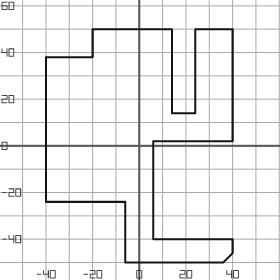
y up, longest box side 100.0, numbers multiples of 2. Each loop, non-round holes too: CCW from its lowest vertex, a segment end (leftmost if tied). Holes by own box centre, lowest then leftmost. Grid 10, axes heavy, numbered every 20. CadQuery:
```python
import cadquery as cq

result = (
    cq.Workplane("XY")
    .moveTo(-6.0, -50.0)
    .lineTo(36.0, -50.0)
    .lineTo(40.0, -46.0)
    .lineTo(40.0, -40.0)
    .lineTo(6.0, -40.0)
    .lineTo(6.0, 2.0)
    .lineTo(40.0, 2.0)
    .lineTo(40.0, 50.0)
    .lineTo(24.0, 50.0)
    .lineTo(24.0, 14.0)
    .lineTo(14.0, 14.0)
    .lineTo(14.0, 50.0)
    .lineTo(-20.0, 50.0)
    .lineTo(-20.0, 38.0)
    .lineTo(-40.0, 38.0)
    .lineTo(-40.0, -24.0)
    .lineTo(-6.0, -24.0)
    .close()
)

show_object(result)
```